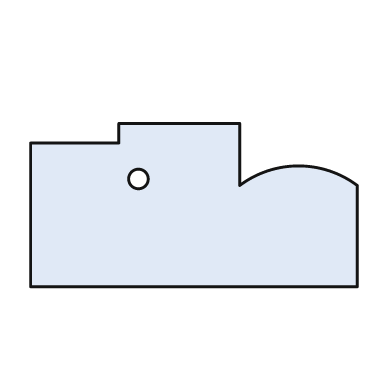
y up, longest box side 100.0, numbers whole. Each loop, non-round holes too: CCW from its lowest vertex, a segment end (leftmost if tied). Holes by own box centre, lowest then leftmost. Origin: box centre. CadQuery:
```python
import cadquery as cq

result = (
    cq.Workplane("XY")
    .moveTo(-50.0, -25.0)
    .lineTo(50.0, -25.0)
    .lineTo(50.0, 6.0)
    .threePointArc((32.0, 12.0), (14.0, 6.0))
    .lineTo(14.0, 25.0)
    .lineTo(-23.0, 25.0)
    .lineTo(-23.0, 19.0)
    .lineTo(-50.0, 19.0)
    .close()
    .moveTo(-17.0, 8.0)
    .circle(3.0)
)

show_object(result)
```